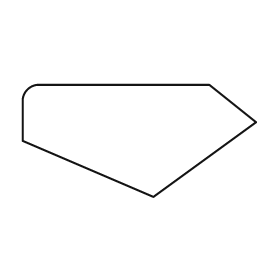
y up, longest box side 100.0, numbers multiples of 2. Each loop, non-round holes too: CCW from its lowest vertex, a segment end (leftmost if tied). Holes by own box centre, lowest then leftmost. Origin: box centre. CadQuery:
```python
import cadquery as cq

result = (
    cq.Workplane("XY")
    .moveTo(6.0, -24.0)
    .lineTo(50.0, 8.0)
    .lineTo(30.0, 24.0)
    .lineTo(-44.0, 24.0)
    .threePointArc((-48.0, 22.0), (-50.0, 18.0))
    .lineTo(-50.0, 0.0)
    .close()
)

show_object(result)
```